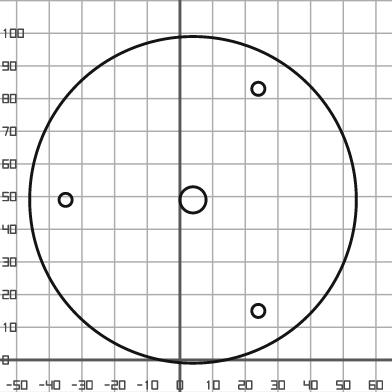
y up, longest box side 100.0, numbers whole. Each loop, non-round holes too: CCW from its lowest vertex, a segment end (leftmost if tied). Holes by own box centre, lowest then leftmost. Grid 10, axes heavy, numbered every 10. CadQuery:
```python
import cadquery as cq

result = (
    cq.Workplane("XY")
    .moveTo(4.0, 49.0)
    .circle(50.0)
    .moveTo(24.0, 15.0)
    .circle(2.0)
    .moveTo(-35.0, 49.0)
    .circle(2.0)
    .moveTo(4.0, 49.0)
    .circle(4.0)
    .moveTo(24.0, 83.0)
    .circle(2.0)
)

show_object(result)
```